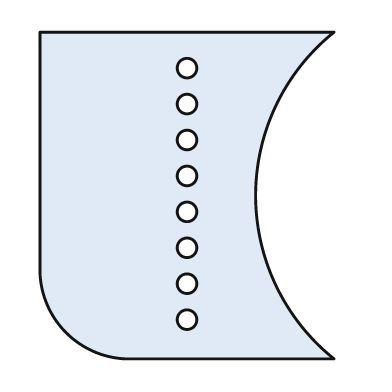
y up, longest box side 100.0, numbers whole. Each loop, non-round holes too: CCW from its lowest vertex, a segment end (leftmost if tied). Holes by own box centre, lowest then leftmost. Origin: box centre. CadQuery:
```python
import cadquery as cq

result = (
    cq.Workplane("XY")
    .moveTo(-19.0, -50.0)
    .lineTo(45.0, -50.0)
    .threePointArc((21.0, 0.0), (45.0, 50.0))
    .lineTo(-45.0, 50.0)
    .lineTo(-45.0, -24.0)
    .threePointArc((-37.0, -42.0), (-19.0, -50.0))
    .close()
    .moveTo(0.0, -38.0)
    .circle(3.0)
    .moveTo(0.0, -27.0)
    .circle(3.0)
    .moveTo(0.0, -16.0)
    .circle(3.0)
    .moveTo(0.0, -5.0)
    .circle(3.0)
    .moveTo(0.0, 6.0)
    .circle(3.0)
    .moveTo(0.0, 17.0)
    .circle(3.0)
    .moveTo(0.0, 28.0)
    .circle(3.0)
    .moveTo(0.0, 39.0)
    .circle(3.0)
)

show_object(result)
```